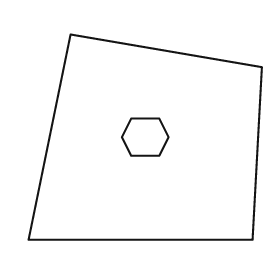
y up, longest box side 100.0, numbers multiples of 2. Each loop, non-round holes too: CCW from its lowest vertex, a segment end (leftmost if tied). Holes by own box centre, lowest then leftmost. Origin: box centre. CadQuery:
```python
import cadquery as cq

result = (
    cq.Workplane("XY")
    .moveTo(-50.0, -44.0)
    .lineTo(46.0, -44.0)
    .lineTo(50.0, 30.0)
    .lineTo(-32.0, 44.0)
    .close()
    .moveTo(-6.0, -8.0)
    .lineTo(6.0, -8.0)
    .lineTo(10.0, 0.0)
    .lineTo(6.0, 8.0)
    .lineTo(-6.0, 8.0)
    .lineTo(-10.0, 0.0)
    .close()
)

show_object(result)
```